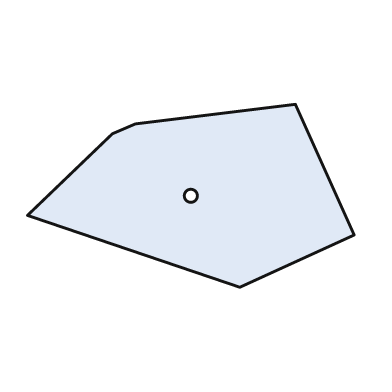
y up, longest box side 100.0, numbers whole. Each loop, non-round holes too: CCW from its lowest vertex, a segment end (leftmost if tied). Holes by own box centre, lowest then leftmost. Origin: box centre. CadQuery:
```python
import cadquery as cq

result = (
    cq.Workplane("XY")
    .moveTo(15.0, -28.0)
    .lineTo(50.0, -12.0)
    .lineTo(32.0, 28.0)
    .lineTo(-17.0, 22.0)
    .lineTo(-24.0, 19.0)
    .lineTo(-50.0, -6.0)
    .close()
    .moveTo(0.0, 0.0)
    .circle(2.0)
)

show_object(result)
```